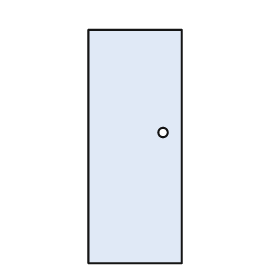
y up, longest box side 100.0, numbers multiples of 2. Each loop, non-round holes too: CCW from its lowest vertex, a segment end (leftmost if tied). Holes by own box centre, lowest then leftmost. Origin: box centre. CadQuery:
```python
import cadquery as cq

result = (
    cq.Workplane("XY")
    .moveTo(-20.0, -50.0)
    .lineTo(20.0, -50.0)
    .lineTo(20.0, 50.0)
    .lineTo(-20.0, 50.0)
    .close()
    .moveTo(12.0, 6.0)
    .circle(2.0)
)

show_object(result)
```